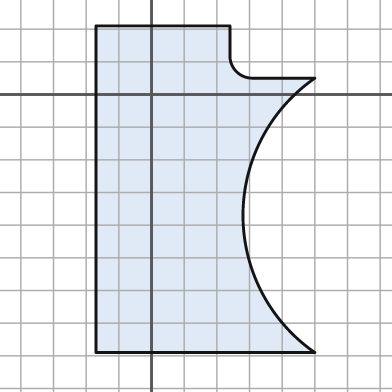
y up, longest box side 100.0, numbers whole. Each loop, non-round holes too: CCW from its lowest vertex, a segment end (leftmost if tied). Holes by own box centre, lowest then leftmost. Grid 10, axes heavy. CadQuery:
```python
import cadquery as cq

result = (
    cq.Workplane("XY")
    .moveTo(-17.0, -79.0)
    .lineTo(50.0, -79.0)
    .threePointArc((28.0, -37.0), (50.0, 5.0))
    .lineTo(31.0, 5.0)
    .threePointArc((26.0, 7.0), (24.0, 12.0))
    .lineTo(24.0, 21.0)
    .lineTo(-17.0, 21.0)
    .close()
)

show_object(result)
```